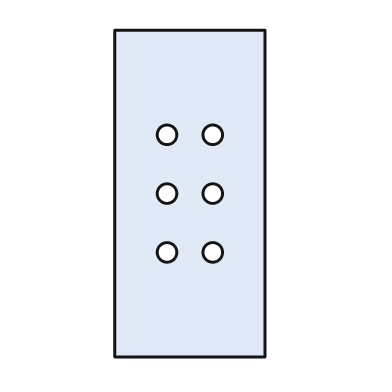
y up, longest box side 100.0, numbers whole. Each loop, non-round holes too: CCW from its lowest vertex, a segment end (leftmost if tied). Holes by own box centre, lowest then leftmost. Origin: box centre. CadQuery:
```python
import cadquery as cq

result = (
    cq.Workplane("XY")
    .moveTo(-23.0, -50.0)
    .lineTo(23.0, -50.0)
    .lineTo(23.0, 50.0)
    .lineTo(-23.0, 50.0)
    .close()
    .moveTo(-7.0, -18.0)
    .circle(3.0)
    .moveTo(7.0, -18.0)
    .circle(3.0)
    .moveTo(-7.0, 0.0)
    .circle(3.0)
    .moveTo(7.0, 0.0)
    .circle(3.0)
    .moveTo(-7.0, 18.0)
    .circle(3.0)
    .moveTo(7.0, 18.0)
    .circle(3.0)
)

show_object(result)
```